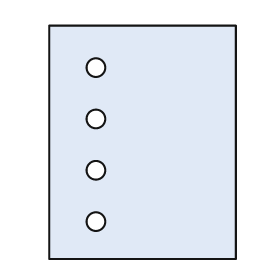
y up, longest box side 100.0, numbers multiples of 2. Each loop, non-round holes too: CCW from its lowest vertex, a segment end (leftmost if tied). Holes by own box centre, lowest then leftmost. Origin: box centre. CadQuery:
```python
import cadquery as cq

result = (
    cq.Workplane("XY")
    .moveTo(-40.0, -50.0)
    .lineTo(40.0, -50.0)
    .lineTo(40.0, 50.0)
    .lineTo(-40.0, 50.0)
    .close()
    .moveTo(-20.0, -34.0)
    .circle(4.0)
    .moveTo(-20.0, -12.0)
    .circle(4.0)
    .moveTo(-20.0, 10.0)
    .circle(4.0)
    .moveTo(-20.0, 32.0)
    .circle(4.0)
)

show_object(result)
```